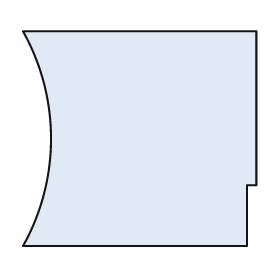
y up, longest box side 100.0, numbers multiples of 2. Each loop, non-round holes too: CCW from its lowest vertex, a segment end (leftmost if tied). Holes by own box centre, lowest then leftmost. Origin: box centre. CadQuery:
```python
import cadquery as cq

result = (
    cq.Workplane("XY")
    .moveTo(-50.0, -46.0)
    .lineTo(46.0, -46.0)
    .lineTo(46.0, -20.0)
    .lineTo(50.0, -20.0)
    .lineTo(50.0, 46.0)
    .lineTo(-50.0, 46.0)
    .threePointArc((-38.0, 0.0), (-50.0, -46.0))
    .close()
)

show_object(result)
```